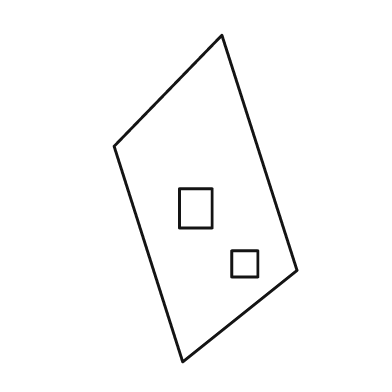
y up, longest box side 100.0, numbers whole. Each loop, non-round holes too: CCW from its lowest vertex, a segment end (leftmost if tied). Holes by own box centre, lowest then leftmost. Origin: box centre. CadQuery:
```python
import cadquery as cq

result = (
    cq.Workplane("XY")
    .moveTo(-7.0, -50.0)
    .lineTo(28.0, -22.0)
    .lineTo(5.0, 50.0)
    .lineTo(-28.0, 16.0)
    .close()
    .moveTo(8.0, -24.0)
    .lineTo(16.0, -24.0)
    .lineTo(16.0, -16.0)
    .lineTo(8.0, -16.0)
    .close()
    .moveTo(-8.0, -9.0)
    .lineTo(2.0, -9.0)
    .lineTo(2.0, 3.0)
    .lineTo(-8.0, 3.0)
    .close()
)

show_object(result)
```